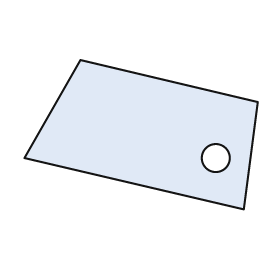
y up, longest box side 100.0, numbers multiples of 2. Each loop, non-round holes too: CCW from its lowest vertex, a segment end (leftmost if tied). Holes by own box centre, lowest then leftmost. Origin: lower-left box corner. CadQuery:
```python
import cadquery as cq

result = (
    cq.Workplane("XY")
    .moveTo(94.0, 0.0)
    .lineTo(100.0, 46.0)
    .lineTo(24.0, 64.0)
    .lineTo(0.0, 22.0)
    .close()
    .moveTo(82.0, 22.0)
    .circle(6.0)
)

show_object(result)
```